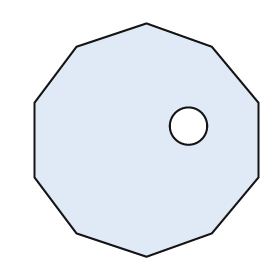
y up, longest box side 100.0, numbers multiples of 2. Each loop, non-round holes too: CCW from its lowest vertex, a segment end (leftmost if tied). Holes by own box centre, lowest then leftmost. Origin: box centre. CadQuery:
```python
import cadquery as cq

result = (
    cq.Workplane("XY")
    .moveTo(0.0, -50.0)
    .lineTo(28.0, -40.0)
    .lineTo(48.0, -16.0)
    .lineTo(48.0, 16.0)
    .lineTo(28.0, 40.0)
    .lineTo(0.0, 50.0)
    .lineTo(-30.0, 40.0)
    .lineTo(-48.0, 16.0)
    .lineTo(-48.0, -16.0)
    .lineTo(-30.0, -40.0)
    .close()
    .moveTo(18.0, 6.0)
    .circle(8.0)
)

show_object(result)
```